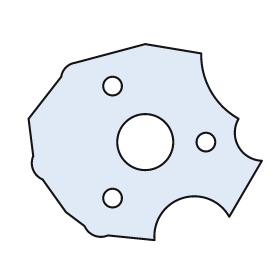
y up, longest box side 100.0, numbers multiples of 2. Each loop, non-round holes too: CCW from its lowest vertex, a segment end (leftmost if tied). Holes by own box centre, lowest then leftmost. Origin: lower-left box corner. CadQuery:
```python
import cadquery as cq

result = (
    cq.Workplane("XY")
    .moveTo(54.0, 0.0)
    .threePointArc((66.0, 18.0), (86.0, 10.0))
    .lineTo(100.0, 34.0)
    .threePointArc((90.0, 40.0), (90.0, 52.0))
    .threePointArc((78.0, 64.0), (74.0, 80.0))
    .lineTo(50.0, 84.0)
    .lineTo(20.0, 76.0)
    .threePointArc((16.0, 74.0), (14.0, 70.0))
    .lineTo(0.0, 52.0)
    .lineTo(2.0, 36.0)
    .threePointArc((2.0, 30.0), (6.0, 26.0))
    .lineTo(16.0, 12.0)
    .lineTo(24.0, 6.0)
    .threePointArc((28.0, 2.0), (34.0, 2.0))
    .close()
    .moveTo(36.0, 18.0)
    .circle(4.0)
    .moveTo(50.0, 42.0)
    .circle(12.0)
    .moveTo(76.0, 42.0)
    .circle(4.0)
    .moveTo(36.0, 66.0)
    .circle(4.0)
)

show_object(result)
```